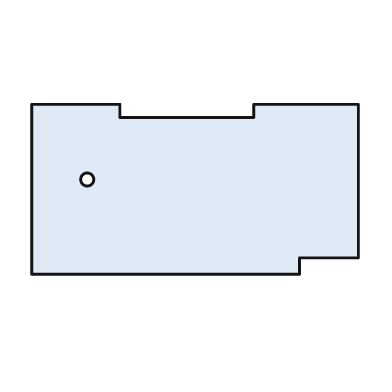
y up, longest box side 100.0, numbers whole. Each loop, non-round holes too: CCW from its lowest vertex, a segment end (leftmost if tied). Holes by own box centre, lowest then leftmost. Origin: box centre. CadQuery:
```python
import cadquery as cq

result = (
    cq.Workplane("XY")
    .moveTo(-50.0, -26.0)
    .lineTo(32.0, -26.0)
    .lineTo(32.0, -21.0)
    .lineTo(50.0, -21.0)
    .lineTo(50.0, 26.0)
    .lineTo(18.0, 26.0)
    .lineTo(18.0, 22.0)
    .lineTo(-23.0, 22.0)
    .lineTo(-23.0, 26.0)
    .lineTo(-50.0, 26.0)
    .close()
    .moveTo(-33.0, 3.0)
    .circle(2.0)
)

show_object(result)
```